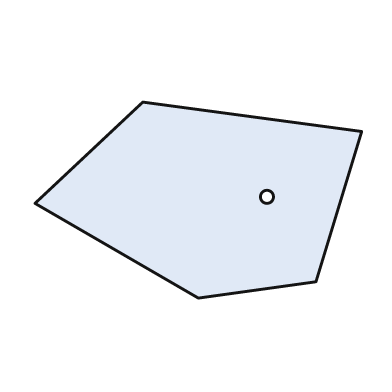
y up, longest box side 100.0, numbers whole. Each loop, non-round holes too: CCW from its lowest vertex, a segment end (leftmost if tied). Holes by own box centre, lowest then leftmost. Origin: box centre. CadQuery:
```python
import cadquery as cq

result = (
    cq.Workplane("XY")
    .moveTo(0.0, -30.0)
    .lineTo(36.0, -25.0)
    .lineTo(50.0, 21.0)
    .lineTo(-17.0, 30.0)
    .lineTo(-50.0, -1.0)
    .close()
    .moveTo(21.0, 1.0)
    .circle(2.0)
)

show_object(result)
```